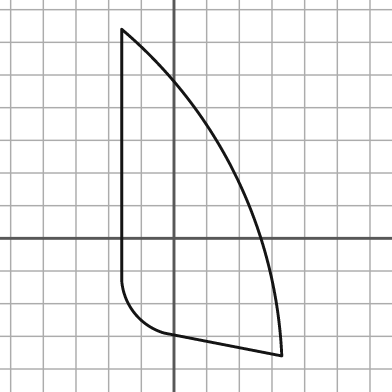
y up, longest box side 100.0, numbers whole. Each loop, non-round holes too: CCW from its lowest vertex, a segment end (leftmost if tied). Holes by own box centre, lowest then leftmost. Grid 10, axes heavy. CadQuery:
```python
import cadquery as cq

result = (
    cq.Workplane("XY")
    .moveTo(33.0, -36.0)
    .threePointArc((19.0, 19.0), (-16.0, 64.0))
    .lineTo(-16.0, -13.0)
    .threePointArc((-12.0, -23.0), (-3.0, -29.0))
    .close()
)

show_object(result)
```